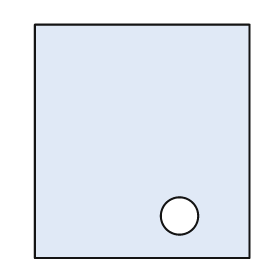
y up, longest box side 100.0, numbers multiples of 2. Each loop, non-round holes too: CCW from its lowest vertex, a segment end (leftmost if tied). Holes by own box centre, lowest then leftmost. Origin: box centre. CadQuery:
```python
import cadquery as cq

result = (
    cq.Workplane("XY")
    .moveTo(-46.0, -50.0)
    .lineTo(46.0, -50.0)
    .lineTo(46.0, 50.0)
    .lineTo(-46.0, 50.0)
    .close()
    .moveTo(16.0, -32.0)
    .circle(8.0)
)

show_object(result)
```